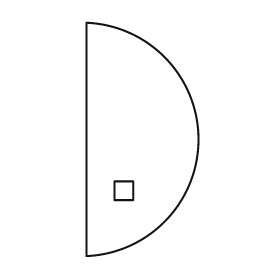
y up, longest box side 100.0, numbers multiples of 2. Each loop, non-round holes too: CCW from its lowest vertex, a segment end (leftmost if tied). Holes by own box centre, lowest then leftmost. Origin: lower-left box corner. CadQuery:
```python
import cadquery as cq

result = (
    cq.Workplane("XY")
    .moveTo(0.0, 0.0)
    .threePointArc((48.0, 50.0), (0.0, 100.0))
    .close()
    .moveTo(12.0, 24.0)
    .lineTo(20.0, 24.0)
    .lineTo(20.0, 32.0)
    .lineTo(12.0, 32.0)
    .close()
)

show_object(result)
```